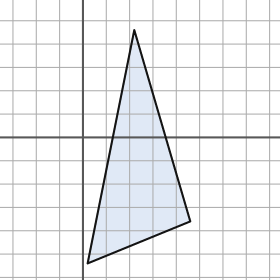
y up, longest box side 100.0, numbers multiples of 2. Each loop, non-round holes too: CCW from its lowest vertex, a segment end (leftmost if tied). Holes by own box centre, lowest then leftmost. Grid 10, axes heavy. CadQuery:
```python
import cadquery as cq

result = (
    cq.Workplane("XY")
    .moveTo(2.0, -54.0)
    .lineTo(46.0, -36.0)
    .lineTo(22.0, 46.0)
    .close()
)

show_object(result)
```